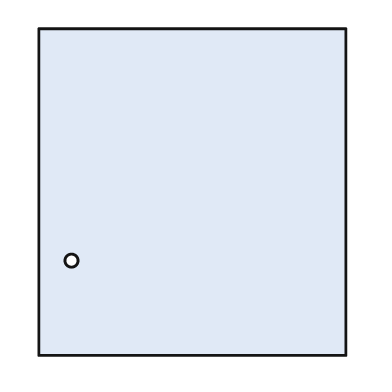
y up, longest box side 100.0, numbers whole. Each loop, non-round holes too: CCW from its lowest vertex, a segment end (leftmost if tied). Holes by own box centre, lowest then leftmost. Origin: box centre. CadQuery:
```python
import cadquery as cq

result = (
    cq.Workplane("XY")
    .moveTo(-47.0, -50.0)
    .lineTo(47.0, -50.0)
    .lineTo(47.0, 50.0)
    .lineTo(-47.0, 50.0)
    .close()
    .moveTo(-37.0, -21.0)
    .circle(2.0)
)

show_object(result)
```